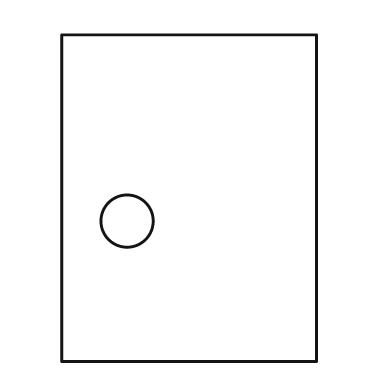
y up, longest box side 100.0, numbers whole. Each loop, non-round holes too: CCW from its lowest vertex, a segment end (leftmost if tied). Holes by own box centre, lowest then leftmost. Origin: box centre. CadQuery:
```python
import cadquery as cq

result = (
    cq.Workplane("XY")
    .moveTo(-39.0, -50.0)
    .lineTo(39.0, -50.0)
    .lineTo(39.0, 50.0)
    .lineTo(-39.0, 50.0)
    .close()
    .moveTo(-19.0, -7.0)
    .circle(8.0)
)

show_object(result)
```